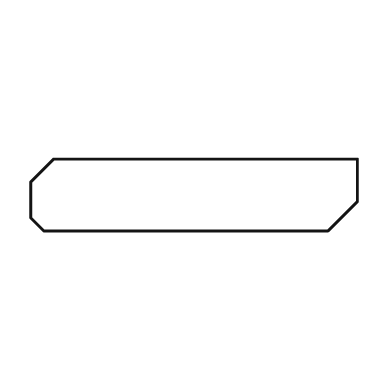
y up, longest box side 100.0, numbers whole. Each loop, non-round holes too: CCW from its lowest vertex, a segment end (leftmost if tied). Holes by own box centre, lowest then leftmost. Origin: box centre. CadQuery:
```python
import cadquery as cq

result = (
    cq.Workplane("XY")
    .moveTo(-46.0, -11.0)
    .lineTo(41.0, -11.0)
    .lineTo(50.0, -2.0)
    .lineTo(50.0, 11.0)
    .lineTo(-43.0, 11.0)
    .lineTo(-50.0, 4.0)
    .lineTo(-50.0, -7.0)
    .close()
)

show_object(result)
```